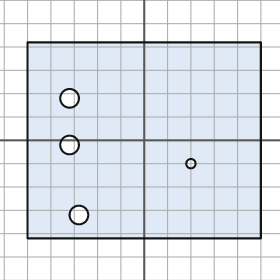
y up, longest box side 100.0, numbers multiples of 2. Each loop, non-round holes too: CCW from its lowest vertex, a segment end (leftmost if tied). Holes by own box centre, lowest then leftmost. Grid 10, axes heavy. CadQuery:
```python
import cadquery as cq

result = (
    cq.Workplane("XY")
    .moveTo(-50.0, -42.0)
    .lineTo(50.0, -42.0)
    .lineTo(50.0, 42.0)
    .lineTo(-50.0, 42.0)
    .close()
    .moveTo(-28.0, -32.0)
    .circle(4.0)
    .moveTo(20.0, -10.0)
    .circle(2.0)
    .moveTo(-32.0, -2.0)
    .circle(4.0)
    .moveTo(-32.0, 18.0)
    .circle(4.0)
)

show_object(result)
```